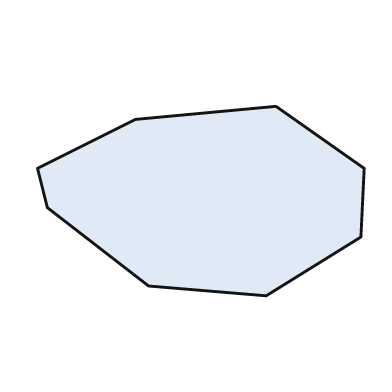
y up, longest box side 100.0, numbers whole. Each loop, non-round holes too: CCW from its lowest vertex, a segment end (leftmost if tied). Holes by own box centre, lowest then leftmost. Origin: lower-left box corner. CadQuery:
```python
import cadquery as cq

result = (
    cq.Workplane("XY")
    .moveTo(70.0, 0.0)
    .lineTo(99.0, 18.0)
    .lineTo(100.0, 39.0)
    .lineTo(73.0, 58.0)
    .lineTo(30.0, 54.0)
    .lineTo(0.0, 39.0)
    .lineTo(3.0, 27.0)
    .lineTo(34.0, 3.0)
    .close()
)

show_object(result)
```